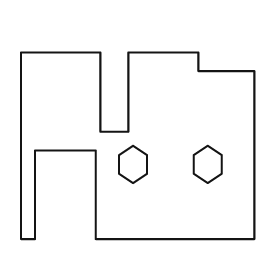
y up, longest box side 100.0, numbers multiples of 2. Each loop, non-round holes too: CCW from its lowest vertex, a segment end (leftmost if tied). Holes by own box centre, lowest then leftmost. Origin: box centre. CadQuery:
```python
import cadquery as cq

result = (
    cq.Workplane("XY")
    .moveTo(-50.0, -40.0)
    .lineTo(-44.0, -40.0)
    .lineTo(-44.0, -2.0)
    .lineTo(-18.0, -2.0)
    .lineTo(-18.0, -40.0)
    .lineTo(50.0, -40.0)
    .lineTo(50.0, 32.0)
    .lineTo(26.0, 32.0)
    .lineTo(26.0, 40.0)
    .lineTo(-4.0, 40.0)
    .lineTo(-4.0, 6.0)
    .lineTo(-16.0, 6.0)
    .lineTo(-16.0, 40.0)
    .lineTo(-50.0, 40.0)
    .close()
    .moveTo(-2.0, -16.0)
    .lineTo(4.0, -12.0)
    .lineTo(4.0, -4.0)
    .lineTo(-2.0, 0.0)
    .lineTo(-8.0, -4.0)
    .lineTo(-8.0, -12.0)
    .close()
    .moveTo(30.0, -16.0)
    .lineTo(36.0, -12.0)
    .lineTo(36.0, -4.0)
    .lineTo(30.0, 0.0)
    .lineTo(24.0, -4.0)
    .lineTo(24.0, -12.0)
    .close()
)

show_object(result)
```